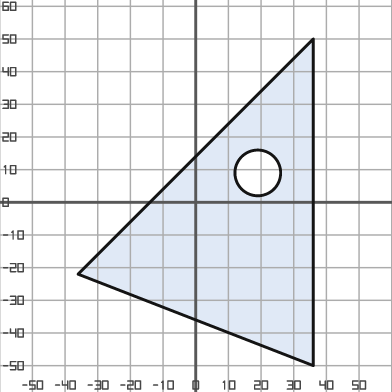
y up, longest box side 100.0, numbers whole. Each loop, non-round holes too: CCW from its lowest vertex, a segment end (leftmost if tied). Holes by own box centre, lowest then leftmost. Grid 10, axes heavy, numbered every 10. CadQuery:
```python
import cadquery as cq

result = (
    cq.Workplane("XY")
    .moveTo(36.0, -50.0)
    .lineTo(36.0, 50.0)
    .lineTo(-36.0, -22.0)
    .close()
    .moveTo(19.0, 9.0)
    .circle(7.0)
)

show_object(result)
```